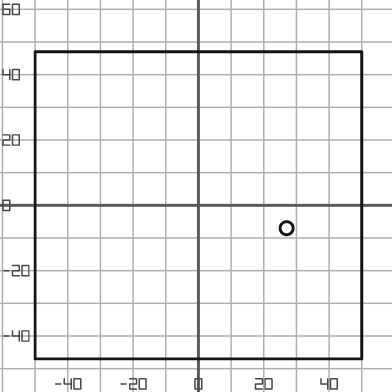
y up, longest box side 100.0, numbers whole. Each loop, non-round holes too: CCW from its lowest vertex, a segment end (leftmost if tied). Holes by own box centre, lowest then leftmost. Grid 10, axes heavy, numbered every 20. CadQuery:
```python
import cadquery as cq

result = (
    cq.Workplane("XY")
    .moveTo(-50.0, -47.0)
    .lineTo(50.0, -47.0)
    .lineTo(50.0, 47.0)
    .lineTo(-50.0, 47.0)
    .close()
    .moveTo(27.0, -7.0)
    .circle(2.0)
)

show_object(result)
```